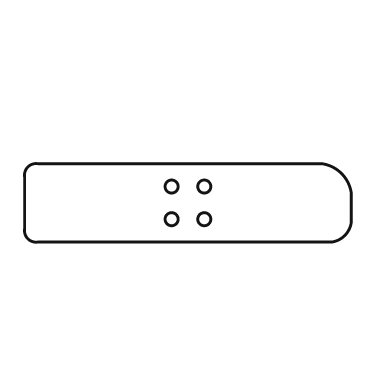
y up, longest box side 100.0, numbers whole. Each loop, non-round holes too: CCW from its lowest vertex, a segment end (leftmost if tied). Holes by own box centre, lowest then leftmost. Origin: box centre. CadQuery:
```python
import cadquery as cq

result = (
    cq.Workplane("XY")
    .moveTo(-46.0, -12.0)
    .lineTo(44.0, -12.0)
    .threePointArc((48.0, -10.0), (50.0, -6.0))
    .lineTo(50.0, 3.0)
    .threePointArc((47.0, 9.0), (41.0, 12.0))
    .lineTo(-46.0, 12.0)
    .threePointArc((-49.0, 11.0), (-50.0, 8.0))
    .lineTo(-50.0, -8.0)
    .threePointArc((-49.0, -11.0), (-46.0, -12.0))
    .close()
    .moveTo(-5.0, -5.0)
    .circle(2.0)
    .moveTo(5.0, -5.0)
    .circle(2.0)
    .moveTo(-5.0, 5.0)
    .circle(2.0)
    .moveTo(5.0, 5.0)
    .circle(2.0)
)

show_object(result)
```